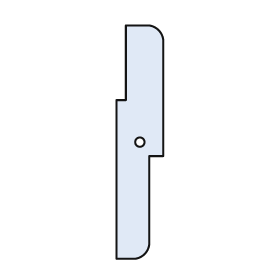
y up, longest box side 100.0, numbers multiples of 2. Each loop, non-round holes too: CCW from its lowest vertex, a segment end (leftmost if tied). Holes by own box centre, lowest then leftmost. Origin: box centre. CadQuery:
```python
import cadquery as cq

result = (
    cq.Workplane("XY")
    .moveTo(-10.0, -50.0)
    .lineTo(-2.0, -50.0)
    .threePointArc((2.0, -48.0), (4.0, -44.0))
    .lineTo(4.0, -6.0)
    .lineTo(10.0, -6.0)
    .lineTo(10.0, 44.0)
    .threePointArc((8.0, 48.0), (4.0, 50.0))
    .lineTo(-6.0, 50.0)
    .lineTo(-6.0, 18.0)
    .lineTo(-10.0, 18.0)
    .close()
    .moveTo(0.0, 0.0)
    .circle(2.0)
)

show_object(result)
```